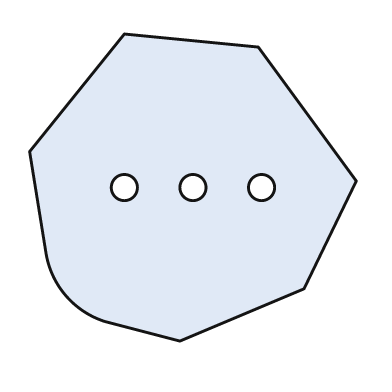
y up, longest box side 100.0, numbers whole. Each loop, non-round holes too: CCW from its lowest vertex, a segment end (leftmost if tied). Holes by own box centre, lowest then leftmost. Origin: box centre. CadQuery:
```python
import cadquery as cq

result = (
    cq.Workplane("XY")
    .moveTo(-4.0, -47.0)
    .lineTo(34.0, -31.0)
    .lineTo(50.0, 2.0)
    .lineTo(20.0, 43.0)
    .lineTo(-21.0, 47.0)
    .lineTo(-50.0, 11.0)
    .lineTo(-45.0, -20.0)
    .threePointArc((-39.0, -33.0), (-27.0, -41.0))
    .close()
    .moveTo(-21.0, 0.0)
    .circle(4.0)
    .moveTo(0.0, 0.0)
    .circle(4.0)
    .moveTo(21.0, 0.0)
    .circle(4.0)
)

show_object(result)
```